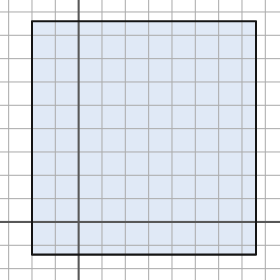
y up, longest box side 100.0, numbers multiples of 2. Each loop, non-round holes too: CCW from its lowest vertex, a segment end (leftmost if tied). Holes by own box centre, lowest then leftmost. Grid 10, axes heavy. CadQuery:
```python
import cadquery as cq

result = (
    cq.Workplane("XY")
    .moveTo(-20.0, -14.0)
    .lineTo(76.0, -14.0)
    .lineTo(76.0, 86.0)
    .lineTo(-20.0, 86.0)
    .close()
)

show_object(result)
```